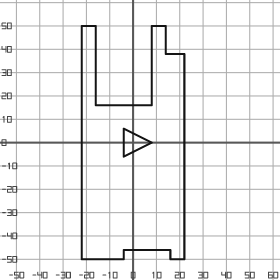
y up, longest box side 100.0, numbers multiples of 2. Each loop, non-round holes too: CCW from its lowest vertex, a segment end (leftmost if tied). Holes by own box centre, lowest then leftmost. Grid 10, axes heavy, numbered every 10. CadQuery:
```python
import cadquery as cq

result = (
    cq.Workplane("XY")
    .moveTo(-22.0, -50.0)
    .lineTo(-4.0, -50.0)
    .lineTo(-4.0, -46.0)
    .lineTo(16.0, -46.0)
    .lineTo(16.0, -50.0)
    .lineTo(22.0, -50.0)
    .lineTo(22.0, 38.0)
    .lineTo(14.0, 38.0)
    .lineTo(14.0, 50.0)
    .lineTo(8.0, 50.0)
    .lineTo(8.0, 16.0)
    .lineTo(-16.0, 16.0)
    .lineTo(-16.0, 50.0)
    .lineTo(-22.0, 50.0)
    .close()
    .moveTo(-4.0, -6.0)
    .lineTo(8.0, 0.0)
    .lineTo(-4.0, 6.0)
    .close()
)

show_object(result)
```